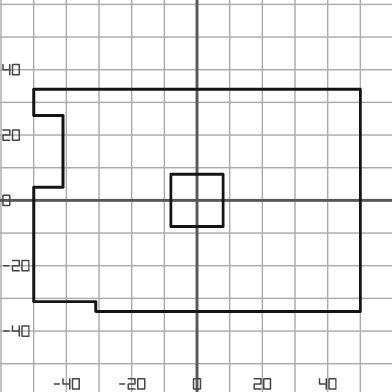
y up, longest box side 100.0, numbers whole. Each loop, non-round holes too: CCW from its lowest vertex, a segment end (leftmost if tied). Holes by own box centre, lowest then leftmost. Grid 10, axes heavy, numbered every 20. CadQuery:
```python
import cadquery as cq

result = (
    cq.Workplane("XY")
    .moveTo(-31.0, -34.0)
    .lineTo(50.0, -34.0)
    .lineTo(50.0, 34.0)
    .lineTo(-50.0, 34.0)
    .lineTo(-50.0, 26.0)
    .lineTo(-41.0, 26.0)
    .lineTo(-41.0, 4.0)
    .lineTo(-50.0, 4.0)
    .lineTo(-50.0, -31.0)
    .lineTo(-31.0, -31.0)
    .close()
    .moveTo(-8.0, -8.0)
    .lineTo(8.0, -8.0)
    .lineTo(8.0, 8.0)
    .lineTo(-8.0, 8.0)
    .close()
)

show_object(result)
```